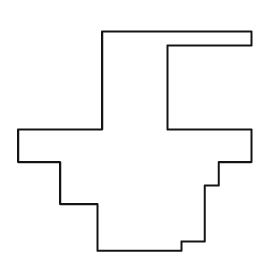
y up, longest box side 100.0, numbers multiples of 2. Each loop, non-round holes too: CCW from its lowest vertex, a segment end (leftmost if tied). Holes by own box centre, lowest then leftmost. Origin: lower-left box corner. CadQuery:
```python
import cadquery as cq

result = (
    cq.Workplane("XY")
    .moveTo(34.0, 0.0)
    .lineTo(70.0, 0.0)
    .lineTo(70.0, 4.0)
    .lineTo(80.0, 4.0)
    .lineTo(80.0, 28.0)
    .lineTo(86.0, 28.0)
    .lineTo(86.0, 38.0)
    .lineTo(100.0, 38.0)
    .lineTo(100.0, 52.0)
    .lineTo(64.0, 52.0)
    .lineTo(64.0, 88.0)
    .lineTo(100.0, 88.0)
    .lineTo(100.0, 94.0)
    .lineTo(36.0, 94.0)
    .lineTo(36.0, 52.0)
    .lineTo(0.0, 52.0)
    .lineTo(0.0, 38.0)
    .lineTo(18.0, 38.0)
    .lineTo(18.0, 20.0)
    .lineTo(34.0, 20.0)
    .close()
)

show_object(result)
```